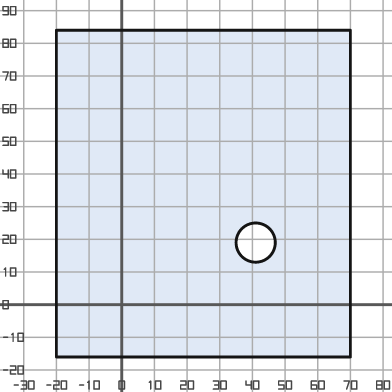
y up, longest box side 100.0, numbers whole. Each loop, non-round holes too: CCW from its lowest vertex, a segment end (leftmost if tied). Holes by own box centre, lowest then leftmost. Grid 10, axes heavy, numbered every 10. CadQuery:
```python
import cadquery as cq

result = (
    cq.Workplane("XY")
    .moveTo(-20.0, -16.0)
    .lineTo(70.0, -16.0)
    .lineTo(70.0, 84.0)
    .lineTo(-20.0, 84.0)
    .close()
    .moveTo(41.0, 19.0)
    .circle(6.0)
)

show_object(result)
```